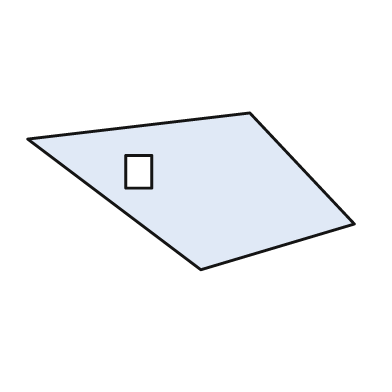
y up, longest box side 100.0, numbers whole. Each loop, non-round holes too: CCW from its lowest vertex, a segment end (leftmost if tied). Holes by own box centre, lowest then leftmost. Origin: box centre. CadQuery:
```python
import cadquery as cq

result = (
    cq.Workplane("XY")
    .moveTo(3.0, -24.0)
    .lineTo(50.0, -10.0)
    .lineTo(18.0, 24.0)
    .lineTo(-50.0, 16.0)
    .close()
    .moveTo(-20.0, 1.0)
    .lineTo(-12.0, 1.0)
    .lineTo(-12.0, 11.0)
    .lineTo(-20.0, 11.0)
    .close()
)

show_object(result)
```